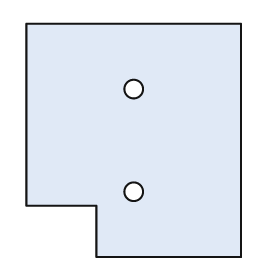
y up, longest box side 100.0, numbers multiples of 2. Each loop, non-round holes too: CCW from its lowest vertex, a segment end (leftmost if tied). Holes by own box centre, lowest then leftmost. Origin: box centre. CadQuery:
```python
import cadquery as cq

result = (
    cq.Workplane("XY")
    .moveTo(-16.0, -50.0)
    .lineTo(46.0, -50.0)
    .lineTo(46.0, 50.0)
    .lineTo(-46.0, 50.0)
    .lineTo(-46.0, -28.0)
    .lineTo(-16.0, -28.0)
    .close()
    .moveTo(0.0, -22.0)
    .circle(4.0)
    .moveTo(0.0, 22.0)
    .circle(4.0)
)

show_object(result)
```